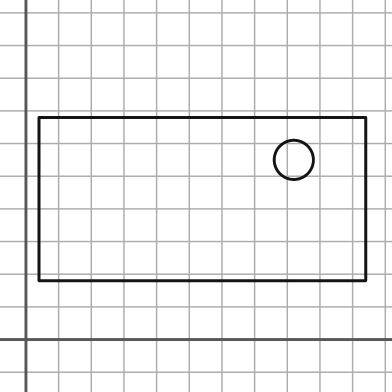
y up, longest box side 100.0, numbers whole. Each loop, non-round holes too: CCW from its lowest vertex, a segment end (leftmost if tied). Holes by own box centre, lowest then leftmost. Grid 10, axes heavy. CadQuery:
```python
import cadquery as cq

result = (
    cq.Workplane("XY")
    .moveTo(4.0, 18.0)
    .lineTo(104.0, 18.0)
    .lineTo(104.0, 68.0)
    .lineTo(4.0, 68.0)
    .close()
    .moveTo(82.0, 55.0)
    .circle(6.0)
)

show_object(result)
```